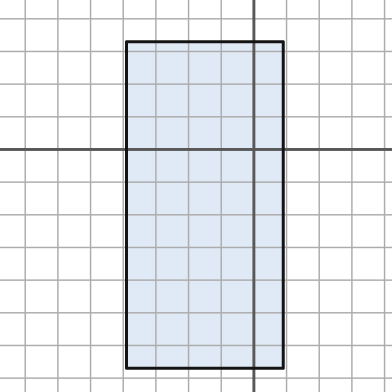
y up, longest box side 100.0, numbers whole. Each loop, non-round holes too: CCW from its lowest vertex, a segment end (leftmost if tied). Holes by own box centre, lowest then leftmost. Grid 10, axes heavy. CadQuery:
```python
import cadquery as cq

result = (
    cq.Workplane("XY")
    .moveTo(-39.0, -67.0)
    .lineTo(9.0, -67.0)
    .lineTo(9.0, 33.0)
    .lineTo(-39.0, 33.0)
    .close()
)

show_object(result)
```